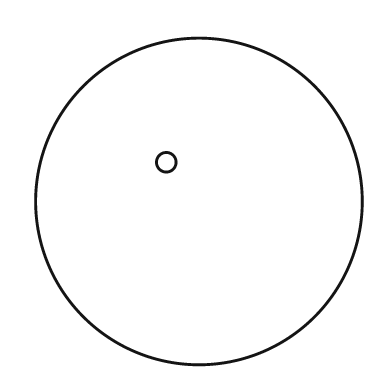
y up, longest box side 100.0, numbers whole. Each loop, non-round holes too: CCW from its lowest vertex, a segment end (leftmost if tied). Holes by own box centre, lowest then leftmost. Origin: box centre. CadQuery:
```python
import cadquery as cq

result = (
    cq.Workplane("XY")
    .moveTo(0.0, 0.0)
    .circle(50.0)
    .moveTo(-10.0, 12.0)
    .circle(3.0)
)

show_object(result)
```